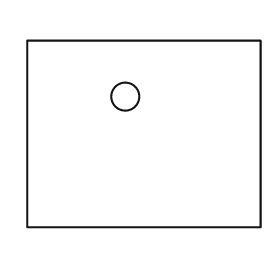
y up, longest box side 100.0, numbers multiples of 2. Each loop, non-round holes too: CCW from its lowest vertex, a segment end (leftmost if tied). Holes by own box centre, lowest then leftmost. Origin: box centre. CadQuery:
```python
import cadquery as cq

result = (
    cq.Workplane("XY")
    .moveTo(-50.0, -40.0)
    .lineTo(50.0, -40.0)
    .lineTo(50.0, 40.0)
    .lineTo(-50.0, 40.0)
    .close()
    .moveTo(-8.0, 16.0)
    .circle(6.0)
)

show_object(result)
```